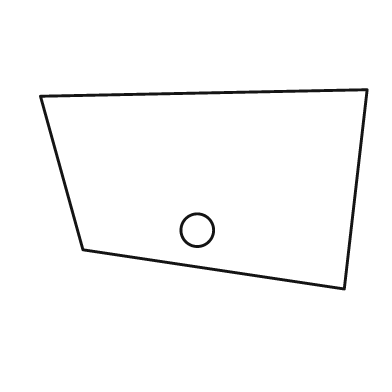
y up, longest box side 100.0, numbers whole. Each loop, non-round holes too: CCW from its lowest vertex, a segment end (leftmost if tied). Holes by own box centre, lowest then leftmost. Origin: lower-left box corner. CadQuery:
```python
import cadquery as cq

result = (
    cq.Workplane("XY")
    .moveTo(93.0, 0.0)
    .lineTo(100.0, 61.0)
    .lineTo(0.0, 59.0)
    .lineTo(13.0, 12.0)
    .close()
    .moveTo(48.0, 18.0)
    .circle(5.0)
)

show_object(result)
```